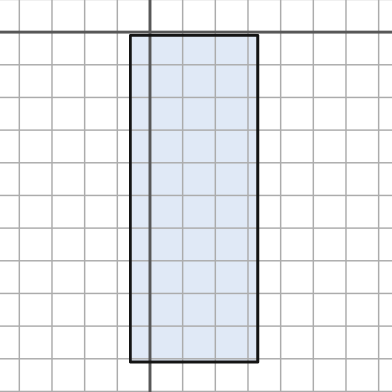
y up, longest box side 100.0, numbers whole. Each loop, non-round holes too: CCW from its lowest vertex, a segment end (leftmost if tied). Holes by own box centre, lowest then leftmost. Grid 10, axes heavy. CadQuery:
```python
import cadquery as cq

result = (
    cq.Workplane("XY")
    .moveTo(-6.0, -101.0)
    .lineTo(33.0, -101.0)
    .lineTo(33.0, -1.0)
    .lineTo(-6.0, -1.0)
    .close()
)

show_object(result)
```